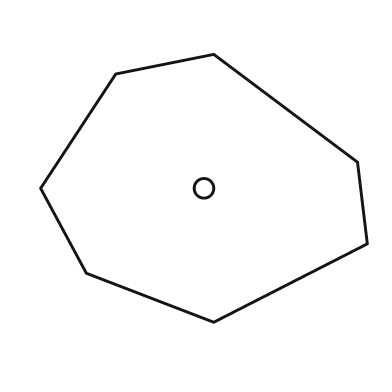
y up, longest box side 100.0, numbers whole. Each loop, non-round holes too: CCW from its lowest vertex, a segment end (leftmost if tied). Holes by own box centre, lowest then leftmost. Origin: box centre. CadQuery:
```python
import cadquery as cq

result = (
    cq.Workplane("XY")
    .moveTo(3.0, -41.0)
    .lineTo(50.0, -17.0)
    .lineTo(47.0, 8.0)
    .lineTo(3.0, 41.0)
    .lineTo(-27.0, 35.0)
    .lineTo(-50.0, 0.0)
    .lineTo(-36.0, -26.0)
    .close()
    .moveTo(0.0, 0.0)
    .circle(3.0)
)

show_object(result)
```